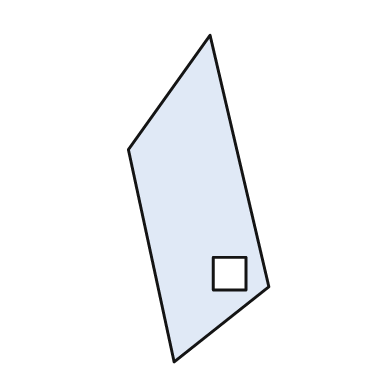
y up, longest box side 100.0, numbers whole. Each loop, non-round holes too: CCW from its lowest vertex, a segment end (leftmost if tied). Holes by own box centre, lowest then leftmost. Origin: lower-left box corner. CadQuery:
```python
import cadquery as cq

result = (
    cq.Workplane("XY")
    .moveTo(14.0, 0.0)
    .lineTo(43.0, 23.0)
    .lineTo(25.0, 100.0)
    .lineTo(0.0, 65.0)
    .close()
    .moveTo(26.0, 22.0)
    .lineTo(36.0, 22.0)
    .lineTo(36.0, 32.0)
    .lineTo(26.0, 32.0)
    .close()
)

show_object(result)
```